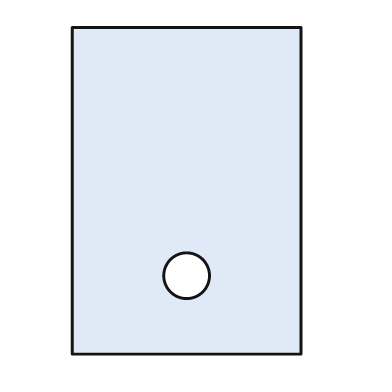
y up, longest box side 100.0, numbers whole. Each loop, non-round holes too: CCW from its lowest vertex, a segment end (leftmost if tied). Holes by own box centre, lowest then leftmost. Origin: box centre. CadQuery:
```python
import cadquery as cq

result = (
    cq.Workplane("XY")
    .moveTo(-35.0, -50.0)
    .lineTo(35.0, -50.0)
    .lineTo(35.0, 50.0)
    .lineTo(-35.0, 50.0)
    .close()
    .moveTo(0.0, -26.0)
    .circle(7.0)
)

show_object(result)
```